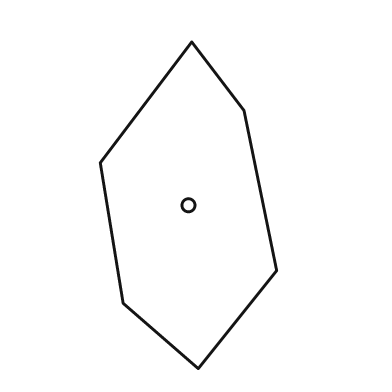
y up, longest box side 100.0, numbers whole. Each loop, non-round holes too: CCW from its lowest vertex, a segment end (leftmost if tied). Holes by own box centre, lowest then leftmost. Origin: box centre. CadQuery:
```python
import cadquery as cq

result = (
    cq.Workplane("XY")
    .moveTo(3.0, -50.0)
    .lineTo(27.0, -20.0)
    .lineTo(17.0, 29.0)
    .lineTo(1.0, 50.0)
    .lineTo(-27.0, 13.0)
    .lineTo(-20.0, -30.0)
    .close()
    .moveTo(0.0, 0.0)
    .circle(2.0)
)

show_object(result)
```